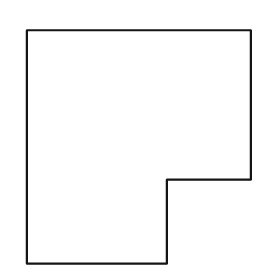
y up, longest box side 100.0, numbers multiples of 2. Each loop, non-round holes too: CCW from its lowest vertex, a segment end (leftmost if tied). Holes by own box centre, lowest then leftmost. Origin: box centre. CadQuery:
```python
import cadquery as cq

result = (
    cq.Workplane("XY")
    .moveTo(-48.0, -50.0)
    .lineTo(12.0, -50.0)
    .lineTo(12.0, -14.0)
    .lineTo(48.0, -14.0)
    .lineTo(48.0, 50.0)
    .lineTo(-48.0, 50.0)
    .close()
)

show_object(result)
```